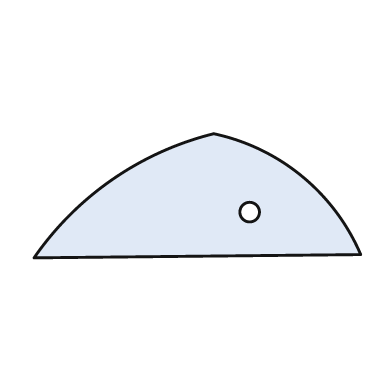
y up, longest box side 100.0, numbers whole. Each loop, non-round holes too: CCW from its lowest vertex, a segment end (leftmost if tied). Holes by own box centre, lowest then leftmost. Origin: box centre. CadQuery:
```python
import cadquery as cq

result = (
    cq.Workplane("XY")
    .moveTo(-50.0, -19.0)
    .lineTo(50.0, -18.0)
    .threePointArc((32.0, 6.0), (5.0, 19.0))
    .threePointArc((-26.0, 5.0), (-50.0, -19.0))
    .close()
    .moveTo(16.0, -5.0)
    .circle(3.0)
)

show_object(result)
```